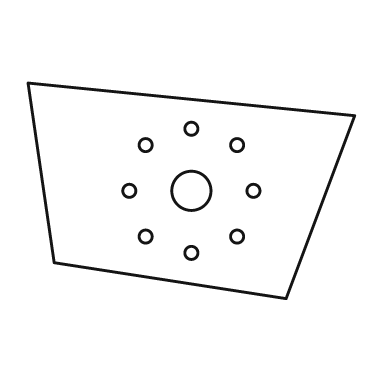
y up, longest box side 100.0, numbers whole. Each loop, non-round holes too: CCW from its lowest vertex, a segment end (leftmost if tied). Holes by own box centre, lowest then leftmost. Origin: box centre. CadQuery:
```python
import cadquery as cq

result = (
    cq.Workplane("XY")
    .moveTo(29.0, -33.0)
    .lineTo(50.0, 23.0)
    .lineTo(-50.0, 33.0)
    .lineTo(-42.0, -22.0)
    .close()
    .moveTo(0.0, -19.0)
    .circle(2.0)
    .moveTo(-14.0, -14.0)
    .circle(2.0)
    .moveTo(14.0, -14.0)
    .circle(2.0)
    .moveTo(-19.0, 0.0)
    .circle(2.0)
    .moveTo(0.0, 0.0)
    .circle(6.0)
    .moveTo(19.0, 0.0)
    .circle(2.0)
    .moveTo(-14.0, 14.0)
    .circle(2.0)
    .moveTo(14.0, 14.0)
    .circle(2.0)
    .moveTo(0.0, 19.0)
    .circle(2.0)
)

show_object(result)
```